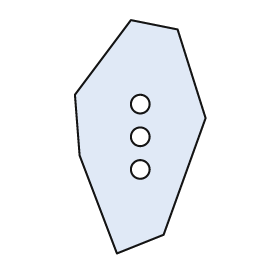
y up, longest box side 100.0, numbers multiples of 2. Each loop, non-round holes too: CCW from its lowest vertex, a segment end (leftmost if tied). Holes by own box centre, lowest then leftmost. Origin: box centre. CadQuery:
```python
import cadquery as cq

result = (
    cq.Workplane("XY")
    .moveTo(-10.0, -50.0)
    .lineTo(10.0, -42.0)
    .lineTo(28.0, 8.0)
    .lineTo(16.0, 46.0)
    .lineTo(-4.0, 50.0)
    .lineTo(-28.0, 18.0)
    .lineTo(-26.0, -8.0)
    .close()
    .moveTo(0.0, -14.0)
    .circle(4.0)
    .moveTo(0.0, 0.0)
    .circle(4.0)
    .moveTo(0.0, 14.0)
    .circle(4.0)
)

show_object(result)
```